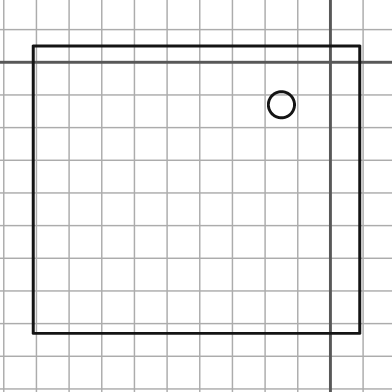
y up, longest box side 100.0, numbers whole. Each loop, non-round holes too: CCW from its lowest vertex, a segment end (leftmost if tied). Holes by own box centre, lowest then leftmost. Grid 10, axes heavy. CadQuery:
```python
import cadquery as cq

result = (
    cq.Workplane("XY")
    .moveTo(-91.0, -83.0)
    .lineTo(9.0, -83.0)
    .lineTo(9.0, 5.0)
    .lineTo(-91.0, 5.0)
    .close()
    .moveTo(-15.0, -13.0)
    .circle(4.0)
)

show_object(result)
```